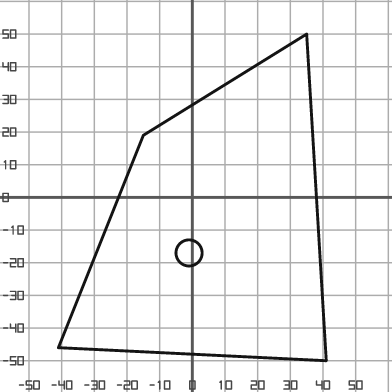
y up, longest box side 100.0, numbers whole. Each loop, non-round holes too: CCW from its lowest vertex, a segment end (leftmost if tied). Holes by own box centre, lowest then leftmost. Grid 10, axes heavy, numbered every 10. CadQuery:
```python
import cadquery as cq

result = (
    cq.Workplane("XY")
    .moveTo(41.0, -50.0)
    .lineTo(35.0, 50.0)
    .lineTo(-15.0, 19.0)
    .lineTo(-41.0, -46.0)
    .close()
    .moveTo(-1.0, -17.0)
    .circle(4.0)
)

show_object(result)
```